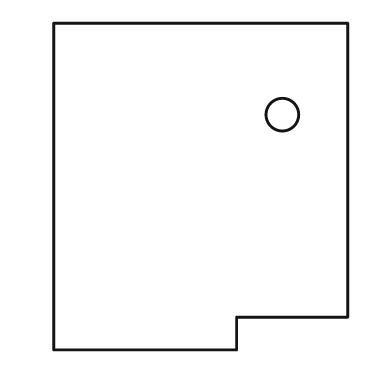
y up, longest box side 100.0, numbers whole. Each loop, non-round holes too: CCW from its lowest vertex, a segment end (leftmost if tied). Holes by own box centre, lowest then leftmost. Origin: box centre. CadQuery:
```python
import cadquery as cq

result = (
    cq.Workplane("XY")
    .moveTo(-45.0, -50.0)
    .lineTo(11.0, -50.0)
    .lineTo(11.0, -40.0)
    .lineTo(45.0, -40.0)
    .lineTo(45.0, 50.0)
    .lineTo(-45.0, 50.0)
    .close()
    .moveTo(25.0, 22.0)
    .circle(5.0)
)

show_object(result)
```